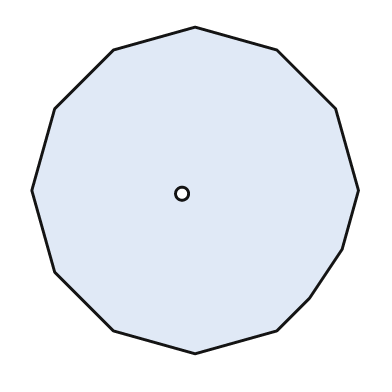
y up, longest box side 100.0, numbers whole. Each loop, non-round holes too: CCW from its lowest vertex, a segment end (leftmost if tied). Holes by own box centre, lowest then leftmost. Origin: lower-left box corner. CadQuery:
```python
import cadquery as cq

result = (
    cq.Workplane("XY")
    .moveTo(50.0, 0.0)
    .lineTo(75.0, 7.0)
    .lineTo(85.0, 17.0)
    .lineTo(95.0, 32.0)
    .lineTo(100.0, 50.0)
    .lineTo(93.0, 75.0)
    .lineTo(75.0, 93.0)
    .lineTo(50.0, 100.0)
    .lineTo(25.0, 93.0)
    .lineTo(7.0, 75.0)
    .lineTo(0.0, 50.0)
    .lineTo(7.0, 25.0)
    .lineTo(25.0, 7.0)
    .close()
    .moveTo(46.0, 49.0)
    .circle(2.0)
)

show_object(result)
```